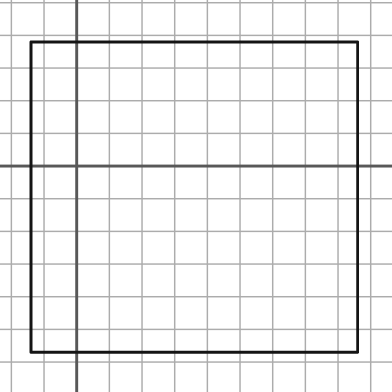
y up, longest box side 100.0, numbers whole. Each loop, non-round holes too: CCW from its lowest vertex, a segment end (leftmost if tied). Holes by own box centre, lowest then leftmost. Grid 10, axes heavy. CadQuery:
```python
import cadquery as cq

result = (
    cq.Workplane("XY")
    .moveTo(-14.0, -57.0)
    .lineTo(86.0, -57.0)
    .lineTo(86.0, 38.0)
    .lineTo(-14.0, 38.0)
    .close()
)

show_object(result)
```